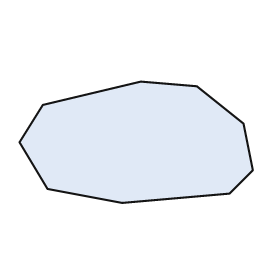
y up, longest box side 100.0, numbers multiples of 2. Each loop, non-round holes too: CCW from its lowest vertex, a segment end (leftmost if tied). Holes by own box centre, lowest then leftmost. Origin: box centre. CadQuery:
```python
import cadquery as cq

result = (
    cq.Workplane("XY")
    .moveTo(-6.0, -26.0)
    .lineTo(40.0, -22.0)
    .lineTo(50.0, -12.0)
    .lineTo(46.0, 8.0)
    .lineTo(26.0, 24.0)
    .lineTo(2.0, 26.0)
    .lineTo(-40.0, 16.0)
    .lineTo(-50.0, 0.0)
    .lineTo(-38.0, -20.0)
    .close()
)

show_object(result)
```